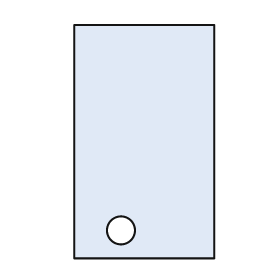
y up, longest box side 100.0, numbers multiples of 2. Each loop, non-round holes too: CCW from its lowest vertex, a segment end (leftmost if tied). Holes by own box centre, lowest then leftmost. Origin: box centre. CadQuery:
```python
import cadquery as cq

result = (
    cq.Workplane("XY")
    .moveTo(-30.0, -50.0)
    .lineTo(30.0, -50.0)
    .lineTo(30.0, 50.0)
    .lineTo(-30.0, 50.0)
    .close()
    .moveTo(-10.0, -38.0)
    .circle(6.0)
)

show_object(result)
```